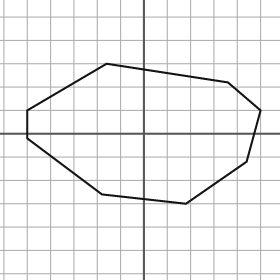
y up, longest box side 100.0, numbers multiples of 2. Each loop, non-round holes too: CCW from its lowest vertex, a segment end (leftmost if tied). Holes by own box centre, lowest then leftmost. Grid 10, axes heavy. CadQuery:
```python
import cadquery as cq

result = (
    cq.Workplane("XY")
    .moveTo(18.0, -30.0)
    .lineTo(44.0, -12.0)
    .lineTo(50.0, 10.0)
    .lineTo(36.0, 22.0)
    .lineTo(-16.0, 30.0)
    .lineTo(-50.0, 10.0)
    .lineTo(-50.0, -2.0)
    .lineTo(-18.0, -26.0)
    .close()
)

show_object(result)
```